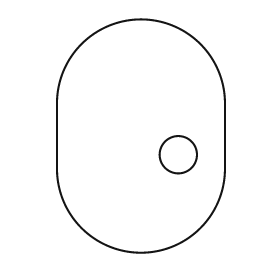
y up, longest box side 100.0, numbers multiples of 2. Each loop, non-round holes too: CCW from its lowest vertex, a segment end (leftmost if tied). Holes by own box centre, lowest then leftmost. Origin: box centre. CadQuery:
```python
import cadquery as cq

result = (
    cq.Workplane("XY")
    .moveTo(-36.0, -14.0)
    .threePointArc((0.0, -50.0), (36.0, -14.0))
    .lineTo(36.0, 14.0)
    .threePointArc((0.0, 50.0), (-36.0, 14.0))
    .close()
    .moveTo(16.0, -8.0)
    .circle(8.0)
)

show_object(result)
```